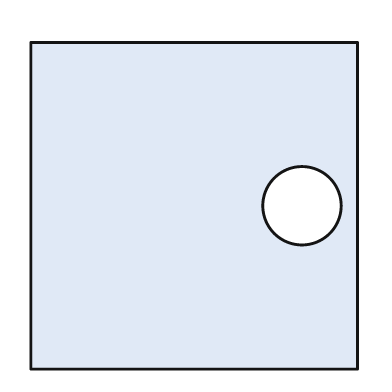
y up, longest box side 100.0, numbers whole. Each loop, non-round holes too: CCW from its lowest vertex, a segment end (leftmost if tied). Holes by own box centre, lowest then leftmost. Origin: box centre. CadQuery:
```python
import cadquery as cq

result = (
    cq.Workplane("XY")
    .moveTo(-50.0, -50.0)
    .lineTo(50.0, -50.0)
    .lineTo(50.0, 50.0)
    .lineTo(-50.0, 50.0)
    .close()
    .moveTo(33.0, 0.0)
    .circle(12.0)
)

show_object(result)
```